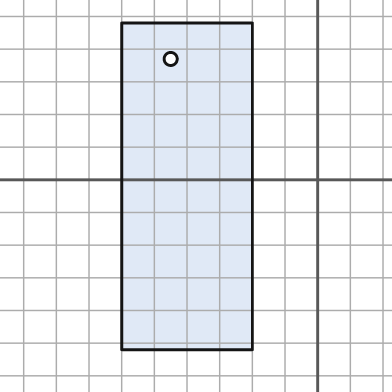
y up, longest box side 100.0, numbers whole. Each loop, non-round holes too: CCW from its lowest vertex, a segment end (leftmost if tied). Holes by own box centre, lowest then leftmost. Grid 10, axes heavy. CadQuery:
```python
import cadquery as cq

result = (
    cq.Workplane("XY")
    .moveTo(-60.0, -52.0)
    .lineTo(-20.0, -52.0)
    .lineTo(-20.0, 48.0)
    .lineTo(-60.0, 48.0)
    .close()
    .moveTo(-45.0, 37.0)
    .circle(2.0)
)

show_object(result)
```